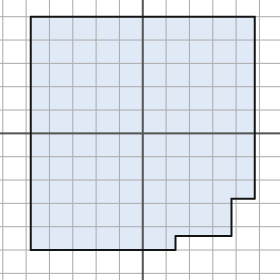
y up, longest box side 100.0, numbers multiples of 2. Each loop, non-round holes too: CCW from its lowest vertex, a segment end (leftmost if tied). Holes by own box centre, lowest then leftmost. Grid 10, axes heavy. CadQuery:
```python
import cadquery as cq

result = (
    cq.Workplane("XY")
    .moveTo(-48.0, -50.0)
    .lineTo(14.0, -50.0)
    .lineTo(14.0, -44.0)
    .lineTo(38.0, -44.0)
    .lineTo(38.0, -28.0)
    .lineTo(48.0, -28.0)
    .lineTo(48.0, 50.0)
    .lineTo(-48.0, 50.0)
    .close()
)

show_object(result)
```